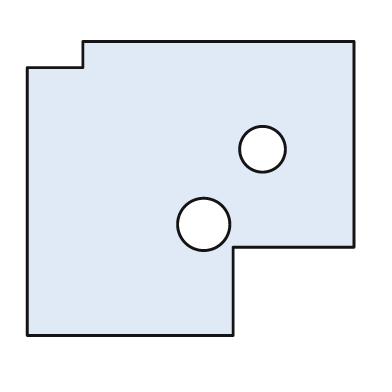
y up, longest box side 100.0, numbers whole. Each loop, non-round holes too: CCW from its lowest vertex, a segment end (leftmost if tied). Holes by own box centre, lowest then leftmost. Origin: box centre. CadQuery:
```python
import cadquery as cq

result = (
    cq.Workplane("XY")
    .moveTo(-50.0, -45.0)
    .lineTo(13.0, -45.0)
    .lineTo(13.0, -18.0)
    .lineTo(50.0, -18.0)
    .lineTo(50.0, 45.0)
    .lineTo(-33.0, 45.0)
    .lineTo(-33.0, 37.0)
    .lineTo(-50.0, 37.0)
    .close()
    .moveTo(4.0, -11.0)
    .circle(8.0)
    .moveTo(22.0, 12.0)
    .circle(7.0)
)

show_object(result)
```